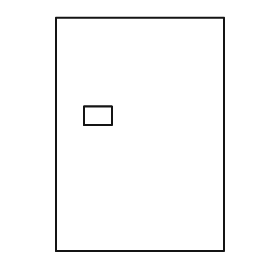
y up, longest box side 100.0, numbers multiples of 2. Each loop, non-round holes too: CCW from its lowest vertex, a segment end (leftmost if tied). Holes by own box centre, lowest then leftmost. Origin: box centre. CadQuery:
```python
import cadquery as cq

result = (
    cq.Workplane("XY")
    .moveTo(-36.0, -50.0)
    .lineTo(36.0, -50.0)
    .lineTo(36.0, 50.0)
    .lineTo(-36.0, 50.0)
    .close()
    .moveTo(-24.0, 4.0)
    .lineTo(-12.0, 4.0)
    .lineTo(-12.0, 12.0)
    .lineTo(-24.0, 12.0)
    .close()
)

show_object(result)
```